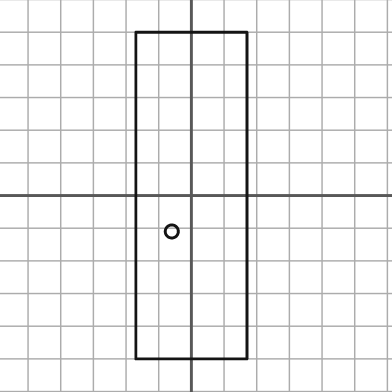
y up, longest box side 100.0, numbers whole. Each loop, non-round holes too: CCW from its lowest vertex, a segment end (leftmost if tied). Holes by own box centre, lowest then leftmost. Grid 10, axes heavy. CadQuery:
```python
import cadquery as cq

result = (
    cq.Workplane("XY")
    .moveTo(-17.0, -50.0)
    .lineTo(17.0, -50.0)
    .lineTo(17.0, 50.0)
    .lineTo(-17.0, 50.0)
    .close()
    .moveTo(-6.0, -11.0)
    .circle(2.0)
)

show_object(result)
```